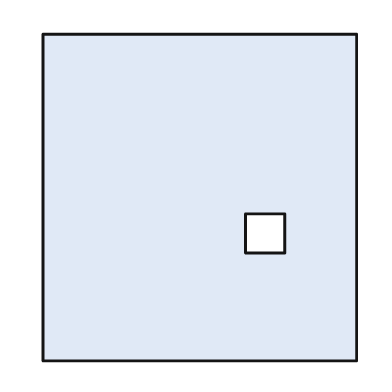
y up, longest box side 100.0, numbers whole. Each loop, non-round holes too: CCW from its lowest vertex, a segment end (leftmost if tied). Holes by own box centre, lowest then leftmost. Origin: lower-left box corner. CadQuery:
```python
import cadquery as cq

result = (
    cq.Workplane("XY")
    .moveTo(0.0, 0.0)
    .lineTo(96.0, 0.0)
    .lineTo(96.0, 100.0)
    .lineTo(0.0, 100.0)
    .close()
    .moveTo(62.0, 33.0)
    .lineTo(74.0, 33.0)
    .lineTo(74.0, 45.0)
    .lineTo(62.0, 45.0)
    .close()
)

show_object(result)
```